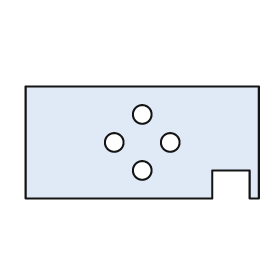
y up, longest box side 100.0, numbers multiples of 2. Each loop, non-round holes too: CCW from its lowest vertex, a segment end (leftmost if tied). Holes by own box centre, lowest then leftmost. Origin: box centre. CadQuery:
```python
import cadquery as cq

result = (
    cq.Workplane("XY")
    .moveTo(-50.0, -24.0)
    .lineTo(30.0, -24.0)
    .lineTo(30.0, -12.0)
    .lineTo(46.0, -12.0)
    .lineTo(46.0, -24.0)
    .lineTo(50.0, -24.0)
    .lineTo(50.0, 24.0)
    .lineTo(-50.0, 24.0)
    .close()
    .moveTo(0.0, -12.0)
    .circle(4.0)
    .moveTo(-12.0, 0.0)
    .circle(4.0)
    .moveTo(12.0, 0.0)
    .circle(4.0)
    .moveTo(0.0, 12.0)
    .circle(4.0)
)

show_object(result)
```